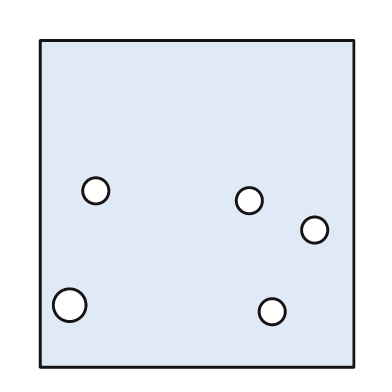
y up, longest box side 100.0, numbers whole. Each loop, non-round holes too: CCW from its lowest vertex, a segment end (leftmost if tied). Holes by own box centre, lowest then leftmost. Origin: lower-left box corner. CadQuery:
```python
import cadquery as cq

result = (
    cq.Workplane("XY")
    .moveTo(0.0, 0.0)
    .lineTo(96.0, 0.0)
    .lineTo(96.0, 100.0)
    .lineTo(0.0, 100.0)
    .close()
    .moveTo(71.0, 17.0)
    .circle(4.0)
    .moveTo(9.0, 19.0)
    .circle(5.0)
    .moveTo(84.0, 42.0)
    .circle(4.0)
    .moveTo(64.0, 51.0)
    .circle(4.0)
    .moveTo(17.0, 54.0)
    .circle(4.0)
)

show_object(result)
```